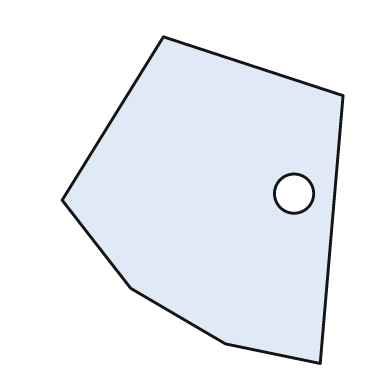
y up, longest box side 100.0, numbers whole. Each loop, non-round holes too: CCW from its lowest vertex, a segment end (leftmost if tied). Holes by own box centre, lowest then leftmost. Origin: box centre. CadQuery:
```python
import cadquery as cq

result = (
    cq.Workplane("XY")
    .moveTo(36.0, -50.0)
    .lineTo(43.0, 32.0)
    .lineTo(-12.0, 50.0)
    .lineTo(-43.0, 0.0)
    .lineTo(-22.0, -27.0)
    .lineTo(7.0, -44.0)
    .close()
    .moveTo(28.0, 2.0)
    .circle(6.0)
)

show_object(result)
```